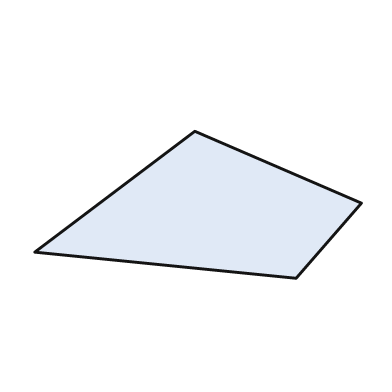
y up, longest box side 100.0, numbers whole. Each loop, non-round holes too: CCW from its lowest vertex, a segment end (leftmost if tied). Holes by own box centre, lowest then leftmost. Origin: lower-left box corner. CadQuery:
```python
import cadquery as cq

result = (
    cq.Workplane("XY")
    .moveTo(80.0, 0.0)
    .lineTo(100.0, 23.0)
    .lineTo(49.0, 45.0)
    .lineTo(0.0, 8.0)
    .close()
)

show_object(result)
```